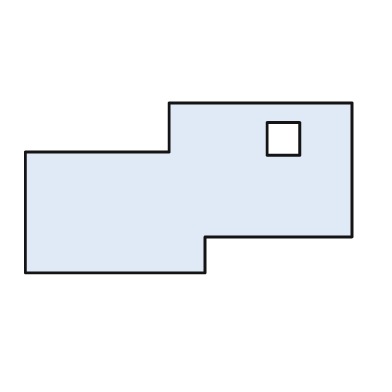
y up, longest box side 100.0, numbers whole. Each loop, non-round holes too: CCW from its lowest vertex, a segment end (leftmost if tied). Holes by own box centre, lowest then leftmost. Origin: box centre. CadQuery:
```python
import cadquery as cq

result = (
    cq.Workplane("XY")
    .moveTo(-50.0, -26.0)
    .lineTo(5.0, -26.0)
    .lineTo(5.0, -15.0)
    .lineTo(50.0, -15.0)
    .lineTo(50.0, 26.0)
    .lineTo(-6.0, 26.0)
    .lineTo(-6.0, 11.0)
    .lineTo(-50.0, 11.0)
    .close()
    .moveTo(24.0, 10.0)
    .lineTo(34.0, 10.0)
    .lineTo(34.0, 20.0)
    .lineTo(24.0, 20.0)
    .close()
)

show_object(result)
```